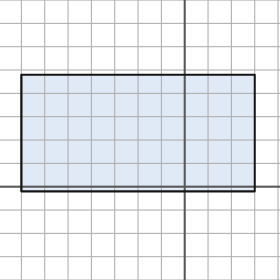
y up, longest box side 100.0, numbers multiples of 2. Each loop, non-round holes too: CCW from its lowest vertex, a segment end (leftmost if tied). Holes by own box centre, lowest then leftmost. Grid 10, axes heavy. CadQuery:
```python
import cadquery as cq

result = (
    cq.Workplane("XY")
    .moveTo(-70.0, -2.0)
    .lineTo(30.0, -2.0)
    .lineTo(30.0, 48.0)
    .lineTo(-70.0, 48.0)
    .close()
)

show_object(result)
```